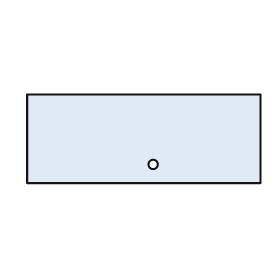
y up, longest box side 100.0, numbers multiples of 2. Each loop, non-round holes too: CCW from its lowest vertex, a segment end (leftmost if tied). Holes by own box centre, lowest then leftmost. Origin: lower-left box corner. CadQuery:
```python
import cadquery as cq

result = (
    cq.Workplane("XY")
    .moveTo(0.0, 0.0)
    .lineTo(100.0, 0.0)
    .lineTo(100.0, 38.0)
    .lineTo(0.0, 38.0)
    .close()
    .moveTo(54.0, 8.0)
    .circle(2.0)
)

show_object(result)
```